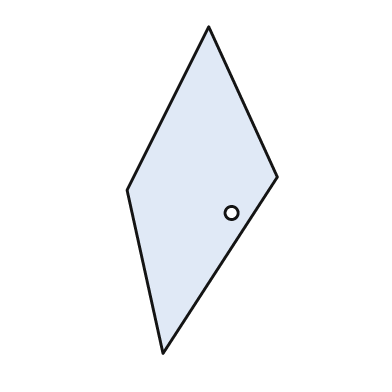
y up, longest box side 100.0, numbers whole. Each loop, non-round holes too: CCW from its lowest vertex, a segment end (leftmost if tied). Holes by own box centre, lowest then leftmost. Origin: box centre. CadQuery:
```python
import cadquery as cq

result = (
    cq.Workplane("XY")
    .moveTo(-12.0, -50.0)
    .lineTo(23.0, 4.0)
    .lineTo(2.0, 50.0)
    .lineTo(-23.0, 0.0)
    .close()
    .moveTo(9.0, -7.0)
    .circle(2.0)
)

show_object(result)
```